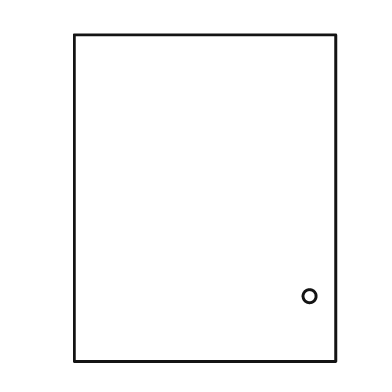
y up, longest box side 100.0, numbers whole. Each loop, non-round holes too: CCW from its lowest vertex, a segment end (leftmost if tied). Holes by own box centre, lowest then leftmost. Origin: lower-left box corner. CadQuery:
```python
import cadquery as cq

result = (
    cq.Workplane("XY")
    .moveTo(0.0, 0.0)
    .lineTo(80.0, 0.0)
    .lineTo(80.0, 100.0)
    .lineTo(0.0, 100.0)
    .close()
    .moveTo(72.0, 20.0)
    .circle(2.0)
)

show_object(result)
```